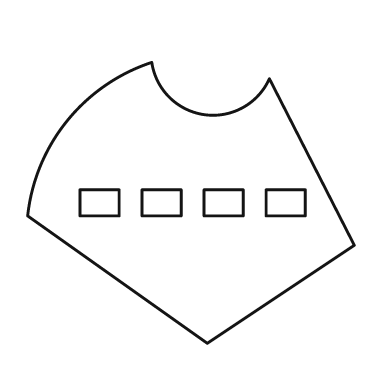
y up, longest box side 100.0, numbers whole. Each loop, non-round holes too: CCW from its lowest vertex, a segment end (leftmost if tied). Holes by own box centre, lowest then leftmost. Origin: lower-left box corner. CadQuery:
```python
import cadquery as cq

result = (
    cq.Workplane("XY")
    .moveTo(55.0, 0.0)
    .lineTo(100.0, 30.0)
    .lineTo(74.0, 81.0)
    .threePointArc((54.0, 70.0), (38.0, 86.0))
    .threePointArc((12.0, 68.0), (0.0, 39.0))
    .close()
    .moveTo(16.0, 39.0)
    .lineTo(28.0, 39.0)
    .lineTo(28.0, 47.0)
    .lineTo(16.0, 47.0)
    .close()
    .moveTo(35.0, 39.0)
    .lineTo(47.0, 39.0)
    .lineTo(47.0, 47.0)
    .lineTo(35.0, 47.0)
    .close()
    .moveTo(54.0, 39.0)
    .lineTo(66.0, 39.0)
    .lineTo(66.0, 47.0)
    .lineTo(54.0, 47.0)
    .close()
    .moveTo(73.0, 39.0)
    .lineTo(85.0, 39.0)
    .lineTo(85.0, 47.0)
    .lineTo(73.0, 47.0)
    .close()
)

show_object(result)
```